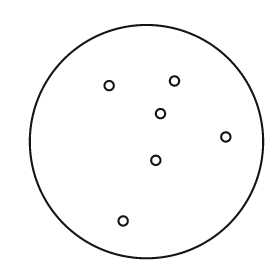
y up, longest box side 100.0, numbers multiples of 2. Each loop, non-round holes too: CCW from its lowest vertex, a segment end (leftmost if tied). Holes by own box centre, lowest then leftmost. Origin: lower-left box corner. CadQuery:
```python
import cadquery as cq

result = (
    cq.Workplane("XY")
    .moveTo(50.0, 50.0)
    .circle(50.0)
    .moveTo(40.0, 16.0)
    .circle(2.0)
    .moveTo(54.0, 42.0)
    .circle(2.0)
    .moveTo(84.0, 52.0)
    .circle(2.0)
    .moveTo(56.0, 62.0)
    .circle(2.0)
    .moveTo(34.0, 74.0)
    .circle(2.0)
    .moveTo(62.0, 76.0)
    .circle(2.0)
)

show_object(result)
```